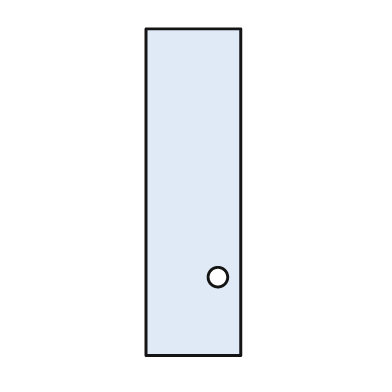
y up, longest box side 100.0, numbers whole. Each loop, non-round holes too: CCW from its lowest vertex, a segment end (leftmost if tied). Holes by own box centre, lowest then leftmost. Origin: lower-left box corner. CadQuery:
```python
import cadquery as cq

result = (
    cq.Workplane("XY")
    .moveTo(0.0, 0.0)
    .lineTo(29.0, 0.0)
    .lineTo(29.0, 100.0)
    .lineTo(0.0, 100.0)
    .close()
    .moveTo(22.0, 24.0)
    .circle(3.0)
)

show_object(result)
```